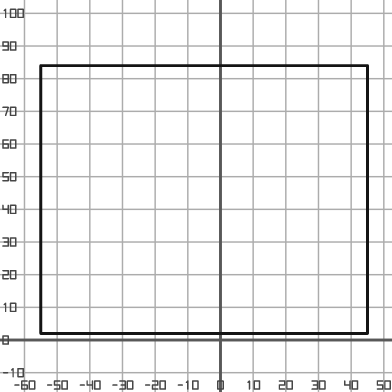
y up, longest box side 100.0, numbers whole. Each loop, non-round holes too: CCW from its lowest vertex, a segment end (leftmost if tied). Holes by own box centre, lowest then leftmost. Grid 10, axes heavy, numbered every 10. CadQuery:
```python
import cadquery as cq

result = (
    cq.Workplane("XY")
    .moveTo(-55.0, 2.0)
    .lineTo(45.0, 2.0)
    .lineTo(45.0, 84.0)
    .lineTo(-55.0, 84.0)
    .close()
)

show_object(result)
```